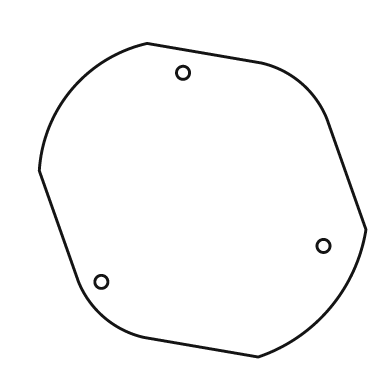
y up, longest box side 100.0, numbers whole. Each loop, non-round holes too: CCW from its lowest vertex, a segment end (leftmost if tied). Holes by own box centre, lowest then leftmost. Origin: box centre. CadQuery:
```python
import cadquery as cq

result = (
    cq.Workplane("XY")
    .moveTo(17.0, -48.0)
    .threePointArc((39.0, -33.0), (50.0, -9.0))
    .lineTo(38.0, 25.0)
    .threePointArc((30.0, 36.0), (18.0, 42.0))
    .lineTo(-17.0, 48.0)
    .threePointArc((-40.0, 34.0), (-50.0, 9.0))
    .lineTo(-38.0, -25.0)
    .threePointArc((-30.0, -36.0), (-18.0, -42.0))
    .close()
    .moveTo(-31.0, -25.0)
    .circle(2.0)
    .moveTo(37.0, -14.0)
    .circle(2.0)
    .moveTo(-6.0, 39.0)
    .circle(2.0)
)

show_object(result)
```